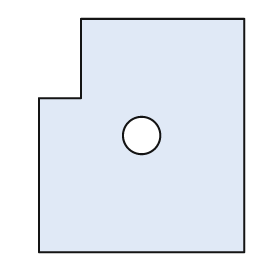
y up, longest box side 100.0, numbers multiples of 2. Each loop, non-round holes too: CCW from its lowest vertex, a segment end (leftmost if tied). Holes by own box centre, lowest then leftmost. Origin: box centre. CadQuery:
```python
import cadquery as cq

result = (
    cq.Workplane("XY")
    .moveTo(-44.0, -50.0)
    .lineTo(44.0, -50.0)
    .lineTo(44.0, 50.0)
    .lineTo(-26.0, 50.0)
    .lineTo(-26.0, 16.0)
    .lineTo(-44.0, 16.0)
    .close()
    .moveTo(0.0, 0.0)
    .circle(8.0)
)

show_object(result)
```